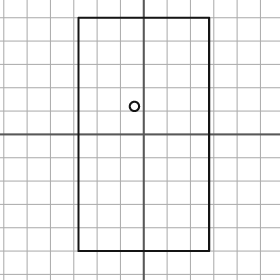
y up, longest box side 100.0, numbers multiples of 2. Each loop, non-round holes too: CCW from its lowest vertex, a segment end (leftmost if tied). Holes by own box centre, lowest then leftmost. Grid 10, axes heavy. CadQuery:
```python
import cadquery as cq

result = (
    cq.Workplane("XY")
    .moveTo(-28.0, -50.0)
    .lineTo(28.0, -50.0)
    .lineTo(28.0, 50.0)
    .lineTo(-28.0, 50.0)
    .close()
    .moveTo(-4.0, 12.0)
    .circle(2.0)
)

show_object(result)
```